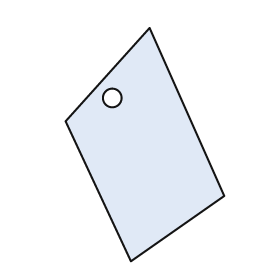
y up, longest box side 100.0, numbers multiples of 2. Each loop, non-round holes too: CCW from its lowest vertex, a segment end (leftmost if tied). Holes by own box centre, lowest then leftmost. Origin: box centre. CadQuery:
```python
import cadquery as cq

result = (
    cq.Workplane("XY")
    .moveTo(-6.0, -50.0)
    .lineTo(34.0, -22.0)
    .lineTo(2.0, 50.0)
    .lineTo(-34.0, 10.0)
    .close()
    .moveTo(-14.0, 20.0)
    .circle(4.0)
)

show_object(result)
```